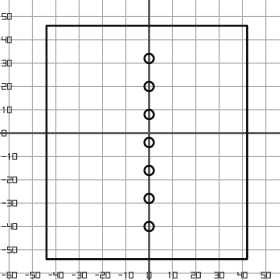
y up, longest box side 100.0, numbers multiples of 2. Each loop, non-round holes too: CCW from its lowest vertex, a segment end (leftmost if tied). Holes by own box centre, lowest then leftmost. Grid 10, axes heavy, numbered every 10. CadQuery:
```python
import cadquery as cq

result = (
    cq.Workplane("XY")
    .moveTo(-44.0, -54.0)
    .lineTo(42.0, -54.0)
    .lineTo(42.0, 46.0)
    .lineTo(-44.0, 46.0)
    .close()
    .moveTo(0.0, -40.0)
    .circle(2.0)
    .moveTo(0.0, -28.0)
    .circle(2.0)
    .moveTo(0.0, -16.0)
    .circle(2.0)
    .moveTo(0.0, -4.0)
    .circle(2.0)
    .moveTo(0.0, 8.0)
    .circle(2.0)
    .moveTo(0.0, 20.0)
    .circle(2.0)
    .moveTo(0.0, 32.0)
    .circle(2.0)
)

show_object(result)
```